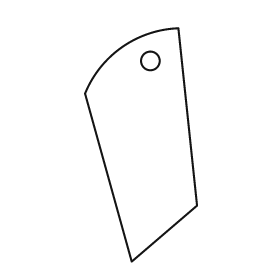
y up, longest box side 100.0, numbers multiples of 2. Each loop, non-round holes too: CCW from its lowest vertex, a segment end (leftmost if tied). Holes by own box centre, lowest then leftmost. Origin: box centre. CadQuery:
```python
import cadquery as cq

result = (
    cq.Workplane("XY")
    .moveTo(-4.0, -50.0)
    .lineTo(24.0, -26.0)
    .lineTo(16.0, 50.0)
    .threePointArc((-8.0, 42.0), (-24.0, 22.0))
    .close()
    .moveTo(4.0, 36.0)
    .circle(4.0)
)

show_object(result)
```